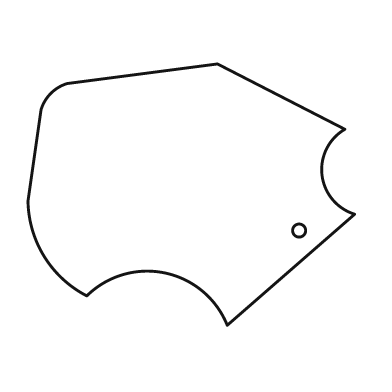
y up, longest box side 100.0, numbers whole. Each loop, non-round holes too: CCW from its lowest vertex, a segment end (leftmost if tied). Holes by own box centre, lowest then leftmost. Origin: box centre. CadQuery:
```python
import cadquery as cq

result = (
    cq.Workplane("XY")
    .moveTo(11.0, -40.0)
    .lineTo(50.0, -6.0)
    .threePointArc((40.0, 6.0), (47.0, 20.0))
    .lineTo(8.0, 40.0)
    .lineTo(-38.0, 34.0)
    .threePointArc((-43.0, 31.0), (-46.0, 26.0))
    .lineTo(-50.0, -2.0)
    .threePointArc((-45.0, -19.0), (-32.0, -31.0))
    .threePointArc((-8.0, -24.0), (11.0, -40.0))
    .close()
    .moveTo(33.0, -11.0)
    .circle(2.0)
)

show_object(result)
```